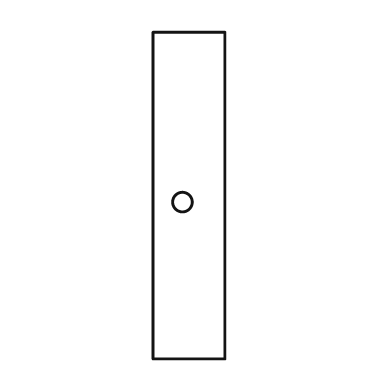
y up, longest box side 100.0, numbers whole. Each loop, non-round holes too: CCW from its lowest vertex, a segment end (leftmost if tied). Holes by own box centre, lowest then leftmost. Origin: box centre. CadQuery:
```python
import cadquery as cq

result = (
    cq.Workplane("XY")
    .moveTo(-11.0, -50.0)
    .lineTo(11.0, -50.0)
    .lineTo(11.0, 50.0)
    .lineTo(-11.0, 50.0)
    .close()
    .moveTo(-2.0, -2.0)
    .circle(3.0)
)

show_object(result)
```